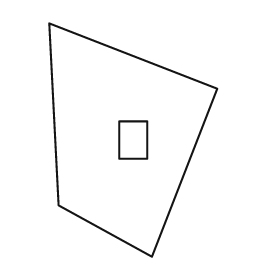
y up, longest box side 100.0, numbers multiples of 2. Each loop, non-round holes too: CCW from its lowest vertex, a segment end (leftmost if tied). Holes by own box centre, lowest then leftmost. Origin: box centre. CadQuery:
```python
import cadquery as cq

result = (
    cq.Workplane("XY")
    .moveTo(8.0, -50.0)
    .lineTo(36.0, 22.0)
    .lineTo(-36.0, 50.0)
    .lineTo(-32.0, -28.0)
    .close()
    .moveTo(-6.0, -8.0)
    .lineTo(6.0, -8.0)
    .lineTo(6.0, 8.0)
    .lineTo(-6.0, 8.0)
    .close()
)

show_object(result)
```